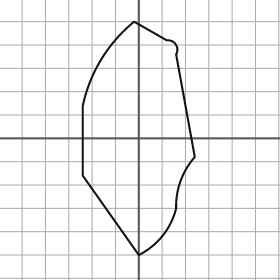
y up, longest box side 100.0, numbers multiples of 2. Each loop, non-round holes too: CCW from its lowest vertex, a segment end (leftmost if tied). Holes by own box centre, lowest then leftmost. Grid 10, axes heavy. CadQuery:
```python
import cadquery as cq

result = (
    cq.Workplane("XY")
    .moveTo(0.0, -50.0)
    .threePointArc((10.0, -42.0), (16.0, -30.0))
    .threePointArc((18.0, -18.0), (24.0, -8.0))
    .lineTo(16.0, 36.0)
    .threePointArc((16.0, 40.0), (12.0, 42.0))
    .lineTo(-2.0, 50.0)
    .threePointArc((-16.0, 34.0), (-24.0, 14.0))
    .lineTo(-24.0, -16.0)
    .close()
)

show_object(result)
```